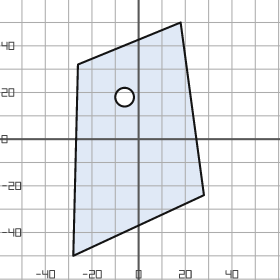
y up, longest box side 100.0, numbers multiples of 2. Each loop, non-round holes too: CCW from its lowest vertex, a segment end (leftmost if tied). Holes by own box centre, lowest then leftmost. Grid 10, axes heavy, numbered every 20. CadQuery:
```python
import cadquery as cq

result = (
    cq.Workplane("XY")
    .moveTo(-28.0, -50.0)
    .lineTo(28.0, -24.0)
    .lineTo(18.0, 50.0)
    .lineTo(-26.0, 32.0)
    .close()
    .moveTo(-6.0, 18.0)
    .circle(4.0)
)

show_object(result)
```